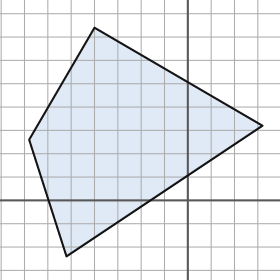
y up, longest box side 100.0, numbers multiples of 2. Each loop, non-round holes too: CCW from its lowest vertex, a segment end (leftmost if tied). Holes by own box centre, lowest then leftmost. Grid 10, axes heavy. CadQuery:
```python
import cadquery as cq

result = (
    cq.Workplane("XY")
    .moveTo(-52.0, -24.0)
    .lineTo(32.0, 32.0)
    .lineTo(-40.0, 74.0)
    .lineTo(-68.0, 26.0)
    .close()
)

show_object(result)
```